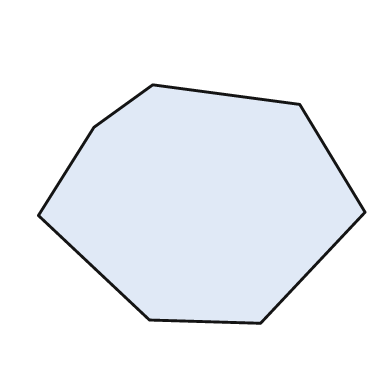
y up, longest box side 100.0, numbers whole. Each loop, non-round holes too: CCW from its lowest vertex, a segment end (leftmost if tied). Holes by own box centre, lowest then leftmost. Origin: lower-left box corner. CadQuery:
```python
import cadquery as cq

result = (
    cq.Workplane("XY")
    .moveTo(68.0, 0.0)
    .lineTo(100.0, 34.0)
    .lineTo(80.0, 67.0)
    .lineTo(35.0, 73.0)
    .lineTo(17.0, 60.0)
    .lineTo(0.0, 33.0)
    .lineTo(34.0, 1.0)
    .close()
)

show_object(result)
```